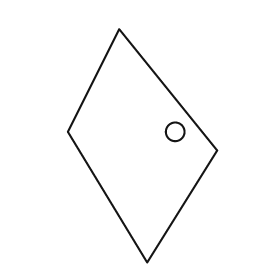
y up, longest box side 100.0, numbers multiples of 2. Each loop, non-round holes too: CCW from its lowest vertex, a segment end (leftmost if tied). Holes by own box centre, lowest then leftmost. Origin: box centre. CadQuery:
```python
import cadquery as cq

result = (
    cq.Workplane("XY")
    .moveTo(2.0, -50.0)
    .lineTo(32.0, -2.0)
    .lineTo(-10.0, 50.0)
    .lineTo(-32.0, 6.0)
    .close()
    .moveTo(14.0, 6.0)
    .circle(4.0)
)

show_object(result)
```